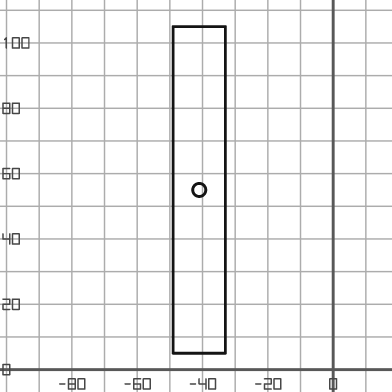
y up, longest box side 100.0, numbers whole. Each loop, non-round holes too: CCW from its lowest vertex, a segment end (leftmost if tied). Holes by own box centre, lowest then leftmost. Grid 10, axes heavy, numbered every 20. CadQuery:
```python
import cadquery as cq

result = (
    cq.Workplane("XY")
    .moveTo(-49.0, 5.0)
    .lineTo(-33.0, 5.0)
    .lineTo(-33.0, 105.0)
    .lineTo(-49.0, 105.0)
    .close()
    .moveTo(-41.0, 55.0)
    .circle(2.0)
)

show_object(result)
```